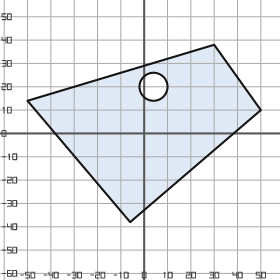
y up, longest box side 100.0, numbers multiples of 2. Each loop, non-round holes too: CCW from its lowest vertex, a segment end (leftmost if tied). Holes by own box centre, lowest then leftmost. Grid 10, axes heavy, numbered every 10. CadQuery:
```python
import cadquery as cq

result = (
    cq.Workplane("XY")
    .moveTo(-6.0, -38.0)
    .lineTo(50.0, 10.0)
    .lineTo(30.0, 38.0)
    .lineTo(-50.0, 14.0)
    .close()
    .moveTo(4.0, 20.0)
    .circle(6.0)
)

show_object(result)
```